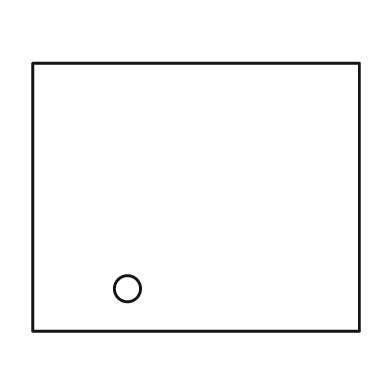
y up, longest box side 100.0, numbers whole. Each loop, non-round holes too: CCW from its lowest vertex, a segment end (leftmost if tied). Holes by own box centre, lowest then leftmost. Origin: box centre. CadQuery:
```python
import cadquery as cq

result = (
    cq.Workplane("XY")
    .moveTo(-50.0, -41.0)
    .lineTo(50.0, -41.0)
    .lineTo(50.0, 41.0)
    .lineTo(-50.0, 41.0)
    .close()
    .moveTo(-21.0, -28.0)
    .circle(4.0)
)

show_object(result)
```